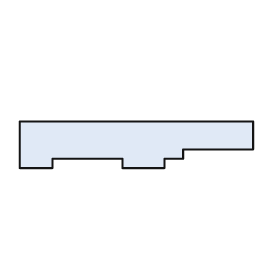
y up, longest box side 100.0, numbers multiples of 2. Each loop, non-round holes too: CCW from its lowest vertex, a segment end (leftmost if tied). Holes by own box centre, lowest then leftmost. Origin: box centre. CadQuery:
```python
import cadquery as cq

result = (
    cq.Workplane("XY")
    .moveTo(-50.0, -10.0)
    .lineTo(-36.0, -10.0)
    .lineTo(-36.0, -6.0)
    .lineTo(-6.0, -6.0)
    .lineTo(-6.0, -10.0)
    .lineTo(12.0, -10.0)
    .lineTo(12.0, -6.0)
    .lineTo(20.0, -6.0)
    .lineTo(20.0, -2.0)
    .lineTo(50.0, -2.0)
    .lineTo(50.0, 10.0)
    .lineTo(-50.0, 10.0)
    .close()
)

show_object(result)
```